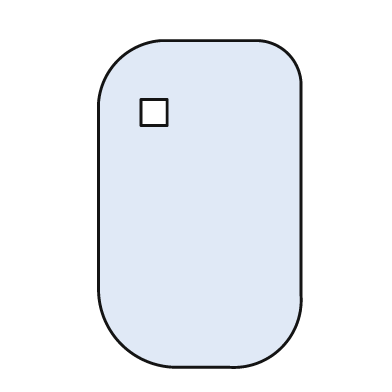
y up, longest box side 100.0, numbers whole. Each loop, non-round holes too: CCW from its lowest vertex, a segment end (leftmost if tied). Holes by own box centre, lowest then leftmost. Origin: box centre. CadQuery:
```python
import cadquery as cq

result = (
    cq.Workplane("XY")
    .moveTo(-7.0, -50.0)
    .lineTo(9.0, -50.0)
    .threePointArc((25.0, -44.0), (31.0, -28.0))
    .lineTo(31.0, 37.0)
    .threePointArc((27.0, 46.0), (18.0, 50.0))
    .lineTo(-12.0, 50.0)
    .threePointArc((-25.0, 44.0), (-31.0, 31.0))
    .lineTo(-31.0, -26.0)
    .threePointArc((-24.0, -43.0), (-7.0, -50.0))
    .close()
    .moveTo(-18.0, 24.0)
    .lineTo(-10.0, 24.0)
    .lineTo(-10.0, 32.0)
    .lineTo(-18.0, 32.0)
    .close()
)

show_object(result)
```